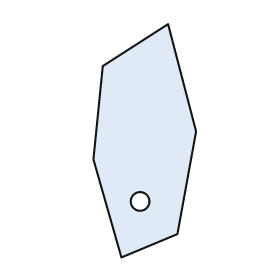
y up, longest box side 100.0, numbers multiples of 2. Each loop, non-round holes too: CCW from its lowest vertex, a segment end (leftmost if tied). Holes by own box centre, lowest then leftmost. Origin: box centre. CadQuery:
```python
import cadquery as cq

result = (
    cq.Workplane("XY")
    .moveTo(-10.0, -50.0)
    .lineTo(14.0, -40.0)
    .lineTo(22.0, 4.0)
    .lineTo(10.0, 50.0)
    .lineTo(-18.0, 32.0)
    .lineTo(-22.0, -8.0)
    .close()
    .moveTo(-2.0, -26.0)
    .circle(4.0)
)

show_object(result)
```